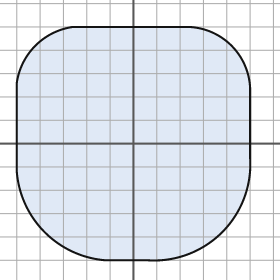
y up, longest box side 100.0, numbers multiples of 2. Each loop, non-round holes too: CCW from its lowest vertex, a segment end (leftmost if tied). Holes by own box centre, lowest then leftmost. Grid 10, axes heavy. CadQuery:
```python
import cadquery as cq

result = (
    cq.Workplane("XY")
    .moveTo(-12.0, -50.0)
    .lineTo(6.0, -50.0)
    .threePointArc((38.0, -38.0), (50.0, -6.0))
    .lineTo(50.0, 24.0)
    .threePointArc((42.0, 42.0), (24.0, 50.0))
    .lineTo(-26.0, 50.0)
    .threePointArc((-42.0, 42.0), (-50.0, 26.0))
    .lineTo(-50.0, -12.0)
    .threePointArc((-38.0, -38.0), (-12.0, -50.0))
    .close()
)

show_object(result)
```